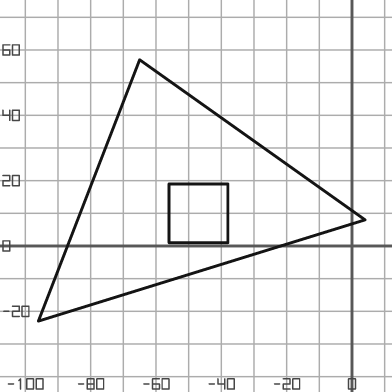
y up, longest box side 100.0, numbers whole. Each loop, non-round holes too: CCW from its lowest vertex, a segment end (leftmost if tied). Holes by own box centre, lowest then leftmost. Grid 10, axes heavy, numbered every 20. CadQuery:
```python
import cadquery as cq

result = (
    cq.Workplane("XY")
    .moveTo(-96.0, -23.0)
    .lineTo(4.0, 8.0)
    .lineTo(-65.0, 57.0)
    .close()
    .moveTo(-56.0, 1.0)
    .lineTo(-38.0, 1.0)
    .lineTo(-38.0, 19.0)
    .lineTo(-56.0, 19.0)
    .close()
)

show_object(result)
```